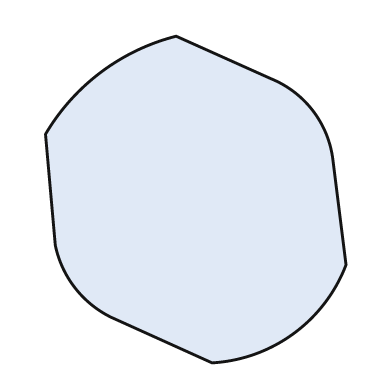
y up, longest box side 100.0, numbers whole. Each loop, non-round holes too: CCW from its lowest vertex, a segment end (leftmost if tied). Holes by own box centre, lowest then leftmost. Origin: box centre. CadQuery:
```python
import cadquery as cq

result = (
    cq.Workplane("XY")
    .moveTo(5.0, -50.0)
    .threePointArc((30.0, -41.0), (46.0, -20.0))
    .lineTo(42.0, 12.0)
    .threePointArc((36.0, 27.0), (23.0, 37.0))
    .lineTo(-6.0, 50.0)
    .threePointArc((-29.0, 39.0), (-46.0, 20.0))
    .lineTo(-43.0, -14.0)
    .threePointArc((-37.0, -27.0), (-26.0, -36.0))
    .close()
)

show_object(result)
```